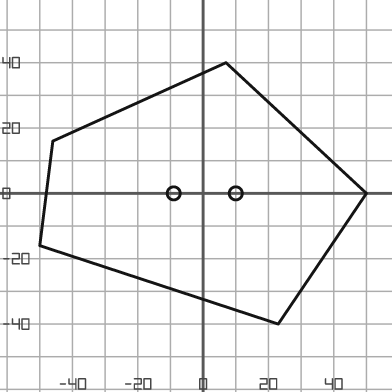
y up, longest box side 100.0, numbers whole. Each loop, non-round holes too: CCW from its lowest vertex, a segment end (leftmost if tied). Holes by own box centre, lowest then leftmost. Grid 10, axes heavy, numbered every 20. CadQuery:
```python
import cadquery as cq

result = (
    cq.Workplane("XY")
    .moveTo(23.0, -40.0)
    .lineTo(50.0, 0.0)
    .lineTo(7.0, 40.0)
    .lineTo(-46.0, 16.0)
    .lineTo(-50.0, -16.0)
    .close()
    .moveTo(-9.0, 0.0)
    .circle(2.0)
    .moveTo(10.0, 0.0)
    .circle(2.0)
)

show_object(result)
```